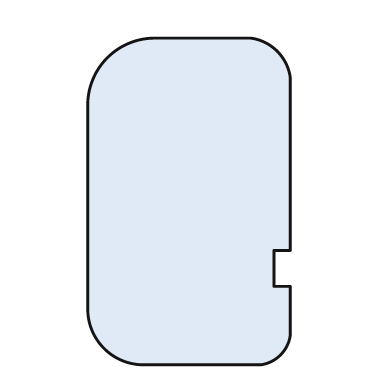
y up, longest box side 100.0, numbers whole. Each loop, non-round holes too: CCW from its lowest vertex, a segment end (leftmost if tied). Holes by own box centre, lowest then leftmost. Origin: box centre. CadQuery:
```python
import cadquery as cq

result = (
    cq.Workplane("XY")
    .moveTo(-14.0, -50.0)
    .lineTo(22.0, -50.0)
    .threePointArc((28.0, -47.0), (31.0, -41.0))
    .lineTo(31.0, -26.0)
    .lineTo(26.0, -26.0)
    .lineTo(26.0, -15.0)
    .lineTo(31.0, -15.0)
    .lineTo(31.0, 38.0)
    .threePointArc((27.0, 46.0), (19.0, 50.0))
    .lineTo(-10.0, 50.0)
    .threePointArc((-25.0, 44.0), (-31.0, 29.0))
    .lineTo(-31.0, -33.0)
    .threePointArc((-26.0, -45.0), (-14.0, -50.0))
    .close()
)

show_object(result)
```